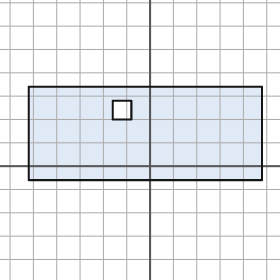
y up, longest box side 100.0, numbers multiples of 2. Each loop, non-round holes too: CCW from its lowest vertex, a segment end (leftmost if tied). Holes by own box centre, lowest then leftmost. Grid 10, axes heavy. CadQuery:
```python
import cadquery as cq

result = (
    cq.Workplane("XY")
    .moveTo(-52.0, -6.0)
    .lineTo(48.0, -6.0)
    .lineTo(48.0, 34.0)
    .lineTo(-52.0, 34.0)
    .close()
    .moveTo(-16.0, 20.0)
    .lineTo(-8.0, 20.0)
    .lineTo(-8.0, 28.0)
    .lineTo(-16.0, 28.0)
    .close()
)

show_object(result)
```